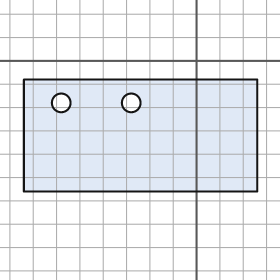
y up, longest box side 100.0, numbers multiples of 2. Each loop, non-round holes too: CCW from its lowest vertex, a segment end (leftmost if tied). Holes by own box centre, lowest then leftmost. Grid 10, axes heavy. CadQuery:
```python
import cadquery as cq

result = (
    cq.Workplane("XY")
    .moveTo(-74.0, -56.0)
    .lineTo(26.0, -56.0)
    .lineTo(26.0, -8.0)
    .lineTo(-74.0, -8.0)
    .close()
    .moveTo(-58.0, -18.0)
    .circle(4.0)
    .moveTo(-28.0, -18.0)
    .circle(4.0)
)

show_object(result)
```